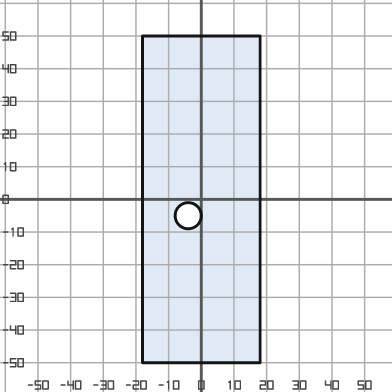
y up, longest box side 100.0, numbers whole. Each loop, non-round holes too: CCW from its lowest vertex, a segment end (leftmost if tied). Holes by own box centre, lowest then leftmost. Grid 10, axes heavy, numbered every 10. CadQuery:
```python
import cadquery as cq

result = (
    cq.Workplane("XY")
    .moveTo(-18.0, -50.0)
    .lineTo(18.0, -50.0)
    .lineTo(18.0, 50.0)
    .lineTo(-18.0, 50.0)
    .close()
    .moveTo(-4.0, -5.0)
    .circle(4.0)
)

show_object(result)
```